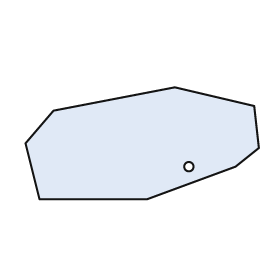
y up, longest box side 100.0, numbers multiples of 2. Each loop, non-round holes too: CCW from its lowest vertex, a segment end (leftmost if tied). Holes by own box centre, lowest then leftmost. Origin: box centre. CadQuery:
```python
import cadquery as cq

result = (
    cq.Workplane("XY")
    .moveTo(-44.0, -24.0)
    .lineTo(2.0, -24.0)
    .lineTo(40.0, -10.0)
    .lineTo(50.0, -2.0)
    .lineTo(48.0, 16.0)
    .lineTo(14.0, 24.0)
    .lineTo(-38.0, 14.0)
    .lineTo(-50.0, 0.0)
    .close()
    .moveTo(20.0, -10.0)
    .circle(2.0)
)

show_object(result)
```